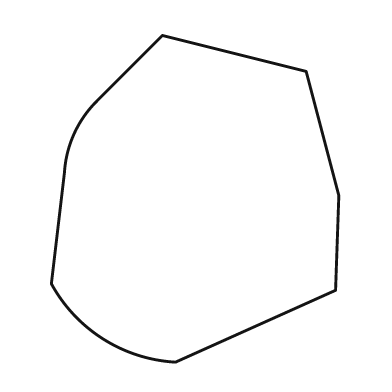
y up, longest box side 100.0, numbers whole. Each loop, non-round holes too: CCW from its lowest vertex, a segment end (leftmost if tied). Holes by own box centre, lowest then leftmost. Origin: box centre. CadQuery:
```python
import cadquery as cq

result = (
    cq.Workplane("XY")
    .moveTo(-6.0, -50.0)
    .lineTo(43.0, -28.0)
    .lineTo(44.0, 1.0)
    .lineTo(34.0, 39.0)
    .lineTo(-10.0, 50.0)
    .lineTo(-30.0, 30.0)
    .threePointArc((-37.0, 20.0), (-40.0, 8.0))
    .lineTo(-44.0, -26.0)
    .threePointArc((-28.0, -43.0), (-6.0, -50.0))
    .close()
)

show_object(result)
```